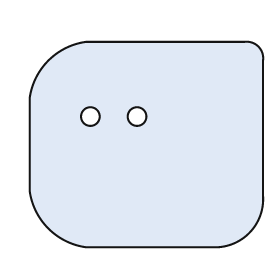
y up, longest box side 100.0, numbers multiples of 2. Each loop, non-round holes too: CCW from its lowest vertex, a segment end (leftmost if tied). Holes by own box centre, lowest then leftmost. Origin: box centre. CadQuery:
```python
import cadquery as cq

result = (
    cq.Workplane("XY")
    .moveTo(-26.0, -44.0)
    .lineTo(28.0, -44.0)
    .threePointArc((44.0, -38.0), (50.0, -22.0))
    .lineTo(50.0, 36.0)
    .threePointArc((48.0, 42.0), (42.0, 44.0))
    .lineTo(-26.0, 44.0)
    .threePointArc((-42.0, 36.0), (-50.0, 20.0))
    .lineTo(-50.0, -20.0)
    .threePointArc((-42.0, -36.0), (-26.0, -44.0))
    .close()
    .moveTo(-24.0, 12.0)
    .circle(4.0)
    .moveTo(-4.0, 12.0)
    .circle(4.0)
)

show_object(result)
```